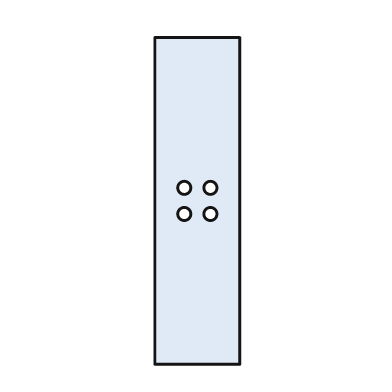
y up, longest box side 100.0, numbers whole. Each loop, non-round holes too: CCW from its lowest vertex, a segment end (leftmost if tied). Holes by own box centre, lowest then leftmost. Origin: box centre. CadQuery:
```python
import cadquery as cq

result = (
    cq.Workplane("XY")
    .moveTo(-13.0, -50.0)
    .lineTo(13.0, -50.0)
    .lineTo(13.0, 50.0)
    .lineTo(-13.0, 50.0)
    .close()
    .moveTo(-4.0, -4.0)
    .circle(2.0)
    .moveTo(4.0, -4.0)
    .circle(2.0)
    .moveTo(-4.0, 4.0)
    .circle(2.0)
    .moveTo(4.0, 4.0)
    .circle(2.0)
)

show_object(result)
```